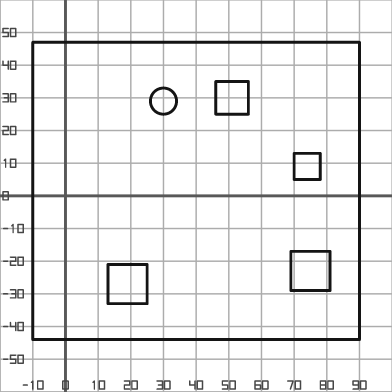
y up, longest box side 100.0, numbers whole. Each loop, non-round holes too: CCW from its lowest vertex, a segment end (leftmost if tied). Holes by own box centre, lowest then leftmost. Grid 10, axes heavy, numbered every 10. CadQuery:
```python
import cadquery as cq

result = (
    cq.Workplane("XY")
    .moveTo(-10.0, -44.0)
    .lineTo(90.0, -44.0)
    .lineTo(90.0, 47.0)
    .lineTo(-10.0, 47.0)
    .close()
    .moveTo(13.0, -33.0)
    .lineTo(25.0, -33.0)
    .lineTo(25.0, -21.0)
    .lineTo(13.0, -21.0)
    .close()
    .moveTo(69.0, -29.0)
    .lineTo(81.0, -29.0)
    .lineTo(81.0, -17.0)
    .lineTo(69.0, -17.0)
    .close()
    .moveTo(70.0, 5.0)
    .lineTo(78.0, 5.0)
    .lineTo(78.0, 13.0)
    .lineTo(70.0, 13.0)
    .close()
    .moveTo(30.0, 29.0)
    .circle(4.0)
    .moveTo(46.0, 25.0)
    .lineTo(56.0, 25.0)
    .lineTo(56.0, 35.0)
    .lineTo(46.0, 35.0)
    .close()
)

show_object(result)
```